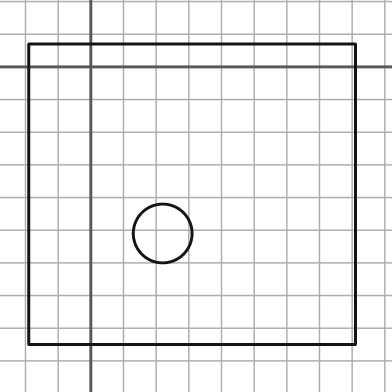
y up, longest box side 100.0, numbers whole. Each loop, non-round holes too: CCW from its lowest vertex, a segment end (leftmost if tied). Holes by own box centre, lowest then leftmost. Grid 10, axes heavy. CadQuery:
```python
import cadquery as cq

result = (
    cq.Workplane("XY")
    .moveTo(-19.0, -85.0)
    .lineTo(81.0, -85.0)
    .lineTo(81.0, 7.0)
    .lineTo(-19.0, 7.0)
    .close()
    .moveTo(22.0, -51.0)
    .circle(9.0)
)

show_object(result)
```